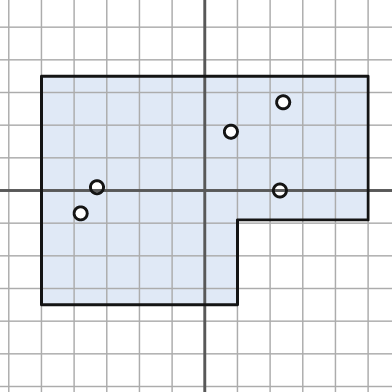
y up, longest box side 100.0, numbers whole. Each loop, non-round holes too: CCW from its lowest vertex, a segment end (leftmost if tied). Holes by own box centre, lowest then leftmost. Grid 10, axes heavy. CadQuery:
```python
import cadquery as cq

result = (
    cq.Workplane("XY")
    .moveTo(-50.0, -35.0)
    .lineTo(10.0, -35.0)
    .lineTo(10.0, -9.0)
    .lineTo(50.0, -9.0)
    .lineTo(50.0, 35.0)
    .lineTo(-50.0, 35.0)
    .close()
    .moveTo(-38.0, -7.0)
    .circle(2.0)
    .moveTo(23.0, 0.0)
    .circle(2.0)
    .moveTo(-33.0, 1.0)
    .circle(2.0)
    .moveTo(8.0, 18.0)
    .circle(2.0)
    .moveTo(24.0, 27.0)
    .circle(2.0)
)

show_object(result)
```